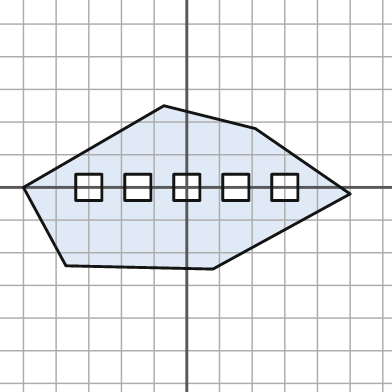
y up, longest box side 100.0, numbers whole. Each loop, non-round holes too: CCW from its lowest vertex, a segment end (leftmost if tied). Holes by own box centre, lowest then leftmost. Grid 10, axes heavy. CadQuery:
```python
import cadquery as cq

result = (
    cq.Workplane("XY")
    .moveTo(8.0, -25.0)
    .lineTo(50.0, -2.0)
    .lineTo(21.0, 18.0)
    .lineTo(-7.0, 25.0)
    .lineTo(-50.0, 0.0)
    .lineTo(-37.0, -24.0)
    .close()
    .moveTo(-34.0, -4.0)
    .lineTo(-26.0, -4.0)
    .lineTo(-26.0, 4.0)
    .lineTo(-34.0, 4.0)
    .close()
    .moveTo(-19.0, -4.0)
    .lineTo(-11.0, -4.0)
    .lineTo(-11.0, 4.0)
    .lineTo(-19.0, 4.0)
    .close()
    .moveTo(-4.0, -4.0)
    .lineTo(4.0, -4.0)
    .lineTo(4.0, 4.0)
    .lineTo(-4.0, 4.0)
    .close()
    .moveTo(11.0, -4.0)
    .lineTo(19.0, -4.0)
    .lineTo(19.0, 4.0)
    .lineTo(11.0, 4.0)
    .close()
    .moveTo(26.0, -4.0)
    .lineTo(34.0, -4.0)
    .lineTo(34.0, 4.0)
    .lineTo(26.0, 4.0)
    .close()
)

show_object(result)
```